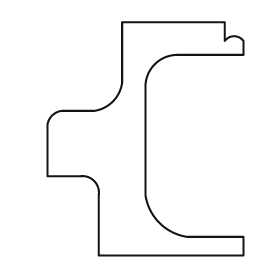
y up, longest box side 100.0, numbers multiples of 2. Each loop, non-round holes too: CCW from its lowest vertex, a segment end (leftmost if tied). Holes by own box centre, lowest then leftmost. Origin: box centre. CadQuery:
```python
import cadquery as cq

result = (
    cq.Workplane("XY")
    .moveTo(-20.0, -50.0)
    .lineTo(42.0, -50.0)
    .lineTo(42.0, -42.0)
    .lineTo(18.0, -42.0)
    .threePointArc((6.0, -36.0), (0.0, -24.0))
    .lineTo(0.0, 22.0)
    .threePointArc((4.0, 32.0), (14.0, 36.0))
    .lineTo(42.0, 36.0)
    .lineTo(42.0, 42.0)
    .threePointArc((38.0, 44.0), (34.0, 42.0))
    .lineTo(34.0, 50.0)
    .lineTo(-10.0, 50.0)
    .lineTo(-10.0, 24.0)
    .threePointArc((-14.0, 16.0), (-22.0, 12.0))
    .lineTo(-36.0, 12.0)
    .threePointArc((-40.0, 10.0), (-42.0, 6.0))
    .lineTo(-42.0, -16.0)
    .lineTo(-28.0, -16.0)
    .threePointArc((-22.0, -18.0), (-20.0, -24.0))
    .close()
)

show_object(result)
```